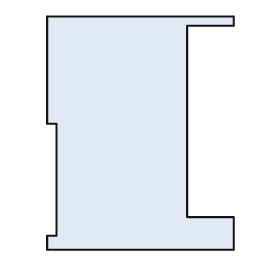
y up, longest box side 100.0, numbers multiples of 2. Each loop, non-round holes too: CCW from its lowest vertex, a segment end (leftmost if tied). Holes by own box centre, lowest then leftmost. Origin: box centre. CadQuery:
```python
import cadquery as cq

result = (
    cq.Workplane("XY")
    .moveTo(-40.0, -50.0)
    .lineTo(40.0, -50.0)
    .lineTo(40.0, -36.0)
    .lineTo(20.0, -36.0)
    .lineTo(20.0, 46.0)
    .lineTo(40.0, 46.0)
    .lineTo(40.0, 50.0)
    .lineTo(-40.0, 50.0)
    .lineTo(-40.0, 4.0)
    .lineTo(-36.0, 4.0)
    .lineTo(-36.0, -44.0)
    .lineTo(-40.0, -44.0)
    .close()
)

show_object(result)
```